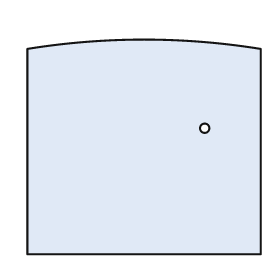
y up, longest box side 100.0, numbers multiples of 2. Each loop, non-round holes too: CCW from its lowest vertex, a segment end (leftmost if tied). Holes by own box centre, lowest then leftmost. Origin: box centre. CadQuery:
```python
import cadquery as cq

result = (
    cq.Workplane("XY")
    .moveTo(-50.0, -46.0)
    .lineTo(50.0, -46.0)
    .lineTo(50.0, 42.0)
    .threePointArc((0.0, 46.0), (-50.0, 42.0))
    .close()
    .moveTo(26.0, 8.0)
    .circle(2.0)
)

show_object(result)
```